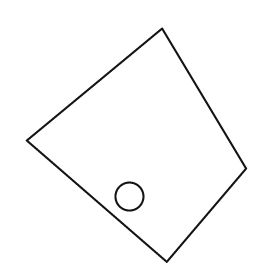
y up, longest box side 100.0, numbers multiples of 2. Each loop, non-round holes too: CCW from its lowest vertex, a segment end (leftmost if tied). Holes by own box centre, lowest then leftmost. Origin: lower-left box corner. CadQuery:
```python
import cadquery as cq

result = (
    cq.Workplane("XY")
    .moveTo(60.0, 0.0)
    .lineTo(94.0, 40.0)
    .lineTo(58.0, 100.0)
    .lineTo(0.0, 52.0)
    .close()
    .moveTo(44.0, 28.0)
    .circle(6.0)
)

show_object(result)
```